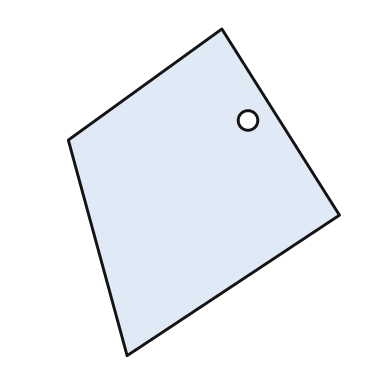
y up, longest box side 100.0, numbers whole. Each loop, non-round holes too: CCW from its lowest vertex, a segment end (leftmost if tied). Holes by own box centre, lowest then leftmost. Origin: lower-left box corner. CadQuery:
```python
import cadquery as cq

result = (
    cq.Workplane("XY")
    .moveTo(18.0, 0.0)
    .lineTo(83.0, 43.0)
    .lineTo(47.0, 100.0)
    .lineTo(0.0, 66.0)
    .close()
    .moveTo(55.0, 72.0)
    .circle(3.0)
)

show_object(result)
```